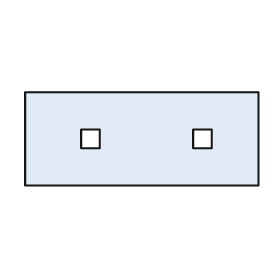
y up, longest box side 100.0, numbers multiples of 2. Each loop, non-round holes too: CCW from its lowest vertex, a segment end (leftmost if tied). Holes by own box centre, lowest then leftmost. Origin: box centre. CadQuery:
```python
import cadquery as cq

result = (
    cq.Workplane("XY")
    .moveTo(-50.0, -20.0)
    .lineTo(50.0, -20.0)
    .lineTo(50.0, 20.0)
    .lineTo(-50.0, 20.0)
    .close()
    .moveTo(-26.0, -4.0)
    .lineTo(-18.0, -4.0)
    .lineTo(-18.0, 4.0)
    .lineTo(-26.0, 4.0)
    .close()
    .moveTo(22.0, -4.0)
    .lineTo(30.0, -4.0)
    .lineTo(30.0, 4.0)
    .lineTo(22.0, 4.0)
    .close()
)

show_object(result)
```